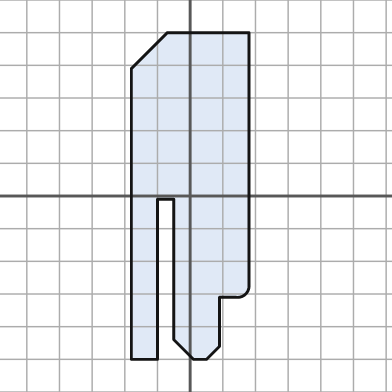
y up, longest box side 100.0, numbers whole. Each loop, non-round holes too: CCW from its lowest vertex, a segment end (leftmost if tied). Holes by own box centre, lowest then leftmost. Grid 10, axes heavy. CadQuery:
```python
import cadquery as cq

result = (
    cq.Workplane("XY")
    .moveTo(-18.0, -50.0)
    .lineTo(-10.0, -50.0)
    .lineTo(-10.0, -1.0)
    .lineTo(-5.0, -1.0)
    .lineTo(-5.0, -44.0)
    .lineTo(1.0, -50.0)
    .lineTo(5.0, -50.0)
    .lineTo(9.0, -46.0)
    .lineTo(9.0, -31.0)
    .lineTo(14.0, -31.0)
    .threePointArc((17.0, -30.0), (18.0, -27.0))
    .lineTo(18.0, 50.0)
    .lineTo(-7.0, 50.0)
    .lineTo(-18.0, 39.0)
    .close()
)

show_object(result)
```